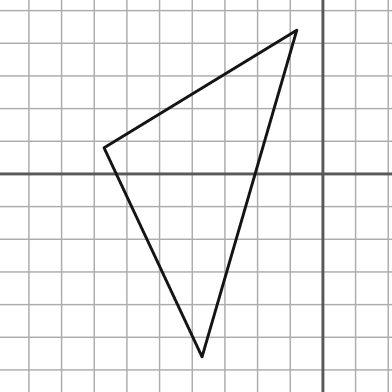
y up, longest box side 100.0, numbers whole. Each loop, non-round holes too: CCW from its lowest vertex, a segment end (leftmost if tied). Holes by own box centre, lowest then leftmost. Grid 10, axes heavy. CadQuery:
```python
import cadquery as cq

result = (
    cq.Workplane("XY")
    .moveTo(-37.0, -56.0)
    .lineTo(-8.0, 44.0)
    .lineTo(-67.0, 8.0)
    .close()
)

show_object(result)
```